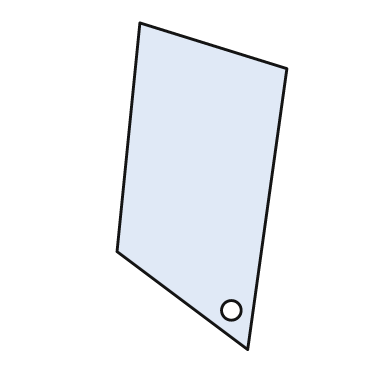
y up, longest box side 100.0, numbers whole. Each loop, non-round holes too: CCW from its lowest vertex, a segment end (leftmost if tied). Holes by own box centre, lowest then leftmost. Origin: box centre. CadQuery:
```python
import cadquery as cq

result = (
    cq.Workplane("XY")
    .moveTo(14.0, -50.0)
    .lineTo(26.0, 36.0)
    .lineTo(-19.0, 50.0)
    .lineTo(-26.0, -20.0)
    .close()
    .moveTo(9.0, -38.0)
    .circle(3.0)
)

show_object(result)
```